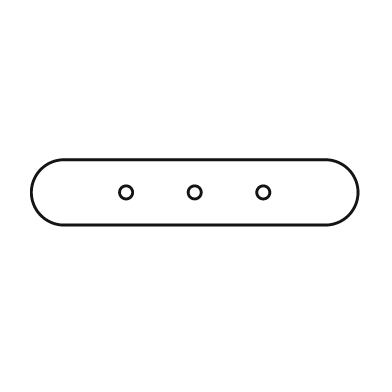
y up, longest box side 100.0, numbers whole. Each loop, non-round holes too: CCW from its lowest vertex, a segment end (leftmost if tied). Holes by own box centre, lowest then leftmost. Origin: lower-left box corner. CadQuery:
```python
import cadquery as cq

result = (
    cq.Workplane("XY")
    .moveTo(10.0, 0.0)
    .lineTo(90.0, 0.0)
    .threePointArc((100.0, 10.0), (90.0, 20.0))
    .lineTo(10.0, 20.0)
    .threePointArc((0.0, 10.0), (10.0, 0.0))
    .close()
    .moveTo(29.0, 10.0)
    .circle(2.0)
    .moveTo(50.0, 10.0)
    .circle(2.0)
    .moveTo(71.0, 10.0)
    .circle(2.0)
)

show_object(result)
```